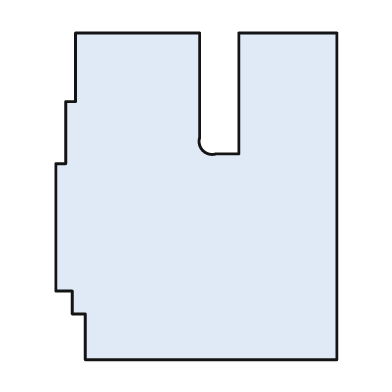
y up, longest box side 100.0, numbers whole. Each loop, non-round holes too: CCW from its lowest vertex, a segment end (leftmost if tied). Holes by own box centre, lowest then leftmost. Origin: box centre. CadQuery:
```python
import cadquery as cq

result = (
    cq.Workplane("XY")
    .moveTo(-34.0, -50.0)
    .lineTo(43.0, -50.0)
    .lineTo(43.0, 50.0)
    .lineTo(13.0, 50.0)
    .lineTo(13.0, 13.0)
    .lineTo(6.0, 13.0)
    .threePointArc((2.0, 14.0), (1.0, 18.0))
    .lineTo(1.0, 50.0)
    .lineTo(-37.0, 50.0)
    .lineTo(-37.0, 29.0)
    .lineTo(-40.0, 29.0)
    .lineTo(-40.0, 10.0)
    .lineTo(-43.0, 10.0)
    .lineTo(-43.0, -29.0)
    .lineTo(-38.0, -29.0)
    .lineTo(-38.0, -36.0)
    .lineTo(-34.0, -36.0)
    .close()
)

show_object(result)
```